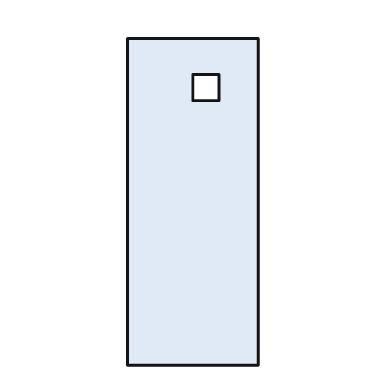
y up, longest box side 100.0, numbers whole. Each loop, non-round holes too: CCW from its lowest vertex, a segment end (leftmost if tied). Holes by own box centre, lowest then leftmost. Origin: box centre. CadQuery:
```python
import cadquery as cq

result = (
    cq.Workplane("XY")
    .moveTo(-20.0, -50.0)
    .lineTo(20.0, -50.0)
    .lineTo(20.0, 50.0)
    .lineTo(-20.0, 50.0)
    .close()
    .moveTo(0.0, 31.0)
    .lineTo(8.0, 31.0)
    .lineTo(8.0, 39.0)
    .lineTo(0.0, 39.0)
    .close()
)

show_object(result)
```